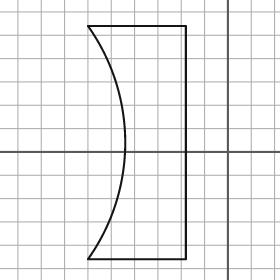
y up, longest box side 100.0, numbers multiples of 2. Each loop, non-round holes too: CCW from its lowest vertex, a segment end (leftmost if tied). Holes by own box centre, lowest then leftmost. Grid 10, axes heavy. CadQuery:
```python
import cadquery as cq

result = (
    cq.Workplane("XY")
    .moveTo(-60.0, -46.0)
    .lineTo(-18.0, -46.0)
    .lineTo(-18.0, 54.0)
    .lineTo(-60.0, 54.0)
    .threePointArc((-44.0, 4.0), (-60.0, -46.0))
    .close()
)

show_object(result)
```